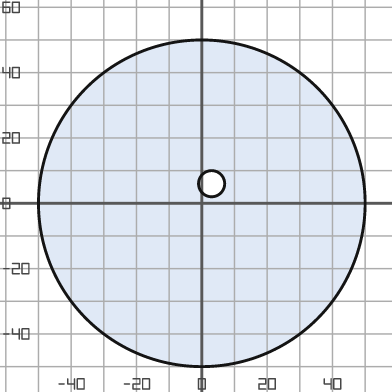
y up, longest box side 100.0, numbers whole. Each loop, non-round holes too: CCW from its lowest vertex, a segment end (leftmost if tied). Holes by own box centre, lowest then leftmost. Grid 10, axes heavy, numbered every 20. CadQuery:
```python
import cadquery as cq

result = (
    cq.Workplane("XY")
    .moveTo(0.0, 0.0)
    .circle(50.0)
    .moveTo(3.0, 6.0)
    .circle(4.0)
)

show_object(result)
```